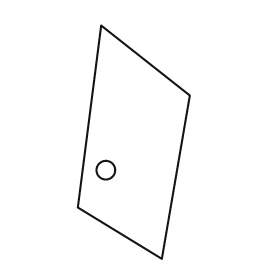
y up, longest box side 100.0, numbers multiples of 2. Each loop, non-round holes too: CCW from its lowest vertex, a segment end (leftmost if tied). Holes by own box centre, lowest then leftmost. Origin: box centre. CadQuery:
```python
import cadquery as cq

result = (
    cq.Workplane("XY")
    .moveTo(12.0, -50.0)
    .lineTo(24.0, 20.0)
    .lineTo(-14.0, 50.0)
    .lineTo(-24.0, -28.0)
    .close()
    .moveTo(-12.0, -12.0)
    .circle(4.0)
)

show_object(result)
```